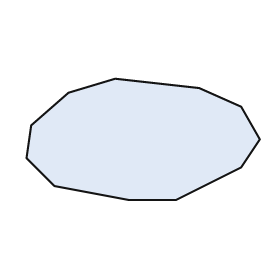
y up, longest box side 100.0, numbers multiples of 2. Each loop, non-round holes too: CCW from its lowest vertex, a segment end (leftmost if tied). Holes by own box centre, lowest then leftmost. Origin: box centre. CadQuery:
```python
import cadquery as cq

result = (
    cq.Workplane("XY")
    .moveTo(-6.0, -26.0)
    .lineTo(14.0, -26.0)
    .lineTo(42.0, -12.0)
    .lineTo(50.0, 0.0)
    .lineTo(42.0, 14.0)
    .lineTo(24.0, 22.0)
    .lineTo(-12.0, 26.0)
    .lineTo(-32.0, 20.0)
    .lineTo(-48.0, 6.0)
    .lineTo(-50.0, -8.0)
    .lineTo(-38.0, -20.0)
    .close()
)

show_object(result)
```